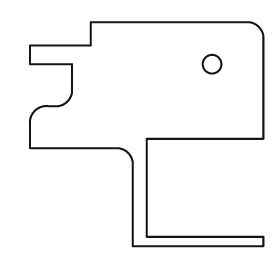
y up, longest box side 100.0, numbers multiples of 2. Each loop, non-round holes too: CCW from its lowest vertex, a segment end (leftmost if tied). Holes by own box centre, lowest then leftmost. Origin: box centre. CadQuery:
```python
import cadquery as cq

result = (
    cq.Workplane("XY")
    .moveTo(-6.0, -48.0)
    .lineTo(50.0, -48.0)
    .lineTo(50.0, -44.0)
    .lineTo(0.0, -44.0)
    .lineTo(0.0, -2.0)
    .lineTo(50.0, -2.0)
    .lineTo(50.0, 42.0)
    .threePointArc((48.0, 46.0), (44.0, 48.0))
    .lineTo(-24.0, 48.0)
    .lineTo(-24.0, 38.0)
    .lineTo(-50.0, 38.0)
    .lineTo(-50.0, 30.0)
    .lineTo(-32.0, 30.0)
    .lineTo(-32.0, 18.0)
    .threePointArc((-34.0, 14.0), (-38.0, 12.0))
    .lineTo(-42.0, 12.0)
    .threePointArc((-48.0, 10.0), (-50.0, 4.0))
    .lineTo(-50.0, -6.0)
    .lineTo(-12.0, -6.0)
    .threePointArc((-8.0, -8.0), (-6.0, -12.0))
    .close()
    .moveTo(28.0, 30.0)
    .circle(4.0)
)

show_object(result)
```